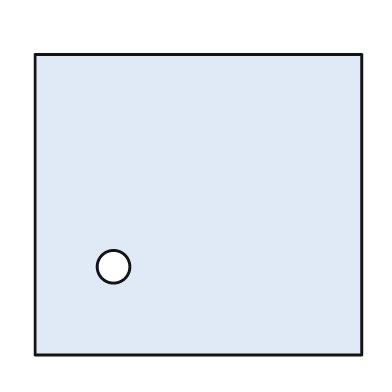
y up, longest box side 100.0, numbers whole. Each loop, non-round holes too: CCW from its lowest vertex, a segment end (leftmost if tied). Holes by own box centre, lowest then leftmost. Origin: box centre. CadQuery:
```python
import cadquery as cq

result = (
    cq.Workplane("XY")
    .moveTo(-50.0, -46.0)
    .lineTo(50.0, -46.0)
    .lineTo(50.0, 46.0)
    .lineTo(-50.0, 46.0)
    .close()
    .moveTo(-26.0, -19.0)
    .circle(5.0)
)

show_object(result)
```